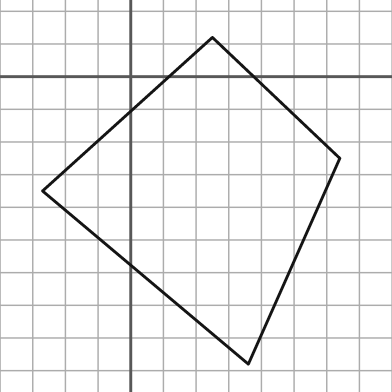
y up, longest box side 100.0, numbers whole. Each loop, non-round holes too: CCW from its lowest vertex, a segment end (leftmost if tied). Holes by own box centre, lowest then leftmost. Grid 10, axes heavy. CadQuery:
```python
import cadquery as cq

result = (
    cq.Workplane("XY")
    .moveTo(36.0, -88.0)
    .lineTo(64.0, -25.0)
    .lineTo(25.0, 12.0)
    .lineTo(-27.0, -35.0)
    .close()
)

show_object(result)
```